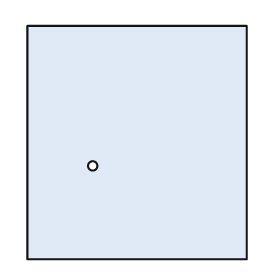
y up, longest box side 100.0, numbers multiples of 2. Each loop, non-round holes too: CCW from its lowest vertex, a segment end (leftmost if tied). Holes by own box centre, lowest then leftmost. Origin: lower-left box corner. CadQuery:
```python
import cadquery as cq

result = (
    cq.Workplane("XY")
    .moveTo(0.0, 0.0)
    .lineTo(94.0, 0.0)
    .lineTo(94.0, 100.0)
    .lineTo(0.0, 100.0)
    .close()
    .moveTo(28.0, 40.0)
    .circle(2.0)
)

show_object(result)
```